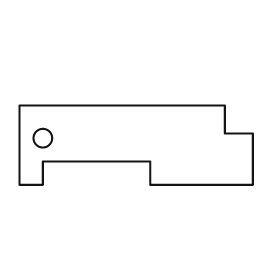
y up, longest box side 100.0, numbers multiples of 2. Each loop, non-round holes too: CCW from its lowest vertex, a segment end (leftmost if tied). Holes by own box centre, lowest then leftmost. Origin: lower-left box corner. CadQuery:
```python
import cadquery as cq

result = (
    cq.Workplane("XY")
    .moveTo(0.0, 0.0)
    .lineTo(10.0, 0.0)
    .lineTo(10.0, 10.0)
    .lineTo(56.0, 10.0)
    .lineTo(56.0, 0.0)
    .lineTo(100.0, 0.0)
    .lineTo(100.0, 22.0)
    .lineTo(88.0, 22.0)
    .lineTo(88.0, 34.0)
    .lineTo(0.0, 34.0)
    .close()
    .moveTo(10.0, 20.0)
    .circle(4.0)
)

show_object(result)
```